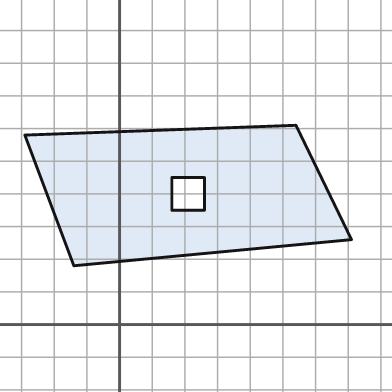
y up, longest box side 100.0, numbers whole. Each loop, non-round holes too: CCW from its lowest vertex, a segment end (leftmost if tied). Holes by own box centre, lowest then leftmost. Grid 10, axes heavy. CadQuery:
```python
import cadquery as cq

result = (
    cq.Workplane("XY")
    .moveTo(-14.0, 18.0)
    .lineTo(71.0, 26.0)
    .lineTo(54.0, 61.0)
    .lineTo(-29.0, 58.0)
    .close()
    .moveTo(16.0, 35.0)
    .lineTo(26.0, 35.0)
    .lineTo(26.0, 45.0)
    .lineTo(16.0, 45.0)
    .close()
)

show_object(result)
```